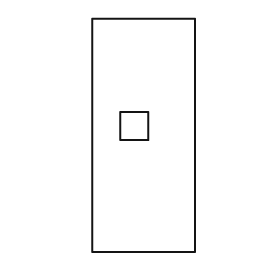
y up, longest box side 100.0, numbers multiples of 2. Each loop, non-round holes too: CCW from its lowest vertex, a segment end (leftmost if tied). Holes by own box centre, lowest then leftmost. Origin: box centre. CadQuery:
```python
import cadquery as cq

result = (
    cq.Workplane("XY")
    .moveTo(-22.0, -50.0)
    .lineTo(22.0, -50.0)
    .lineTo(22.0, 50.0)
    .lineTo(-22.0, 50.0)
    .close()
    .moveTo(-10.0, -2.0)
    .lineTo(2.0, -2.0)
    .lineTo(2.0, 10.0)
    .lineTo(-10.0, 10.0)
    .close()
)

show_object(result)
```